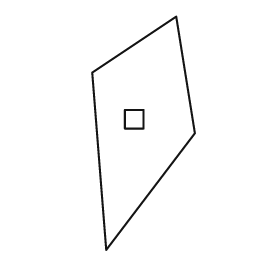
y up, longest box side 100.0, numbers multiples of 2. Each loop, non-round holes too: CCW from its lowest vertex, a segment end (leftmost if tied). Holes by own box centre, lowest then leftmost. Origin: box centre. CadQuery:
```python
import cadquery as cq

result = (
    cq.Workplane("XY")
    .moveTo(-16.0, -50.0)
    .lineTo(22.0, 0.0)
    .lineTo(14.0, 50.0)
    .lineTo(-22.0, 26.0)
    .close()
    .moveTo(-8.0, 2.0)
    .lineTo(0.0, 2.0)
    .lineTo(0.0, 10.0)
    .lineTo(-8.0, 10.0)
    .close()
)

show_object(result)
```